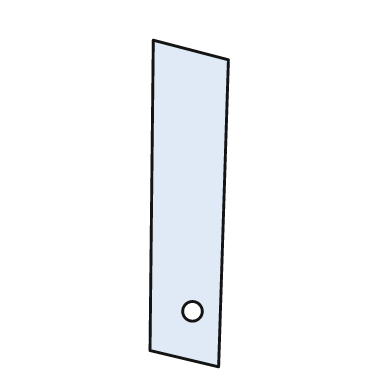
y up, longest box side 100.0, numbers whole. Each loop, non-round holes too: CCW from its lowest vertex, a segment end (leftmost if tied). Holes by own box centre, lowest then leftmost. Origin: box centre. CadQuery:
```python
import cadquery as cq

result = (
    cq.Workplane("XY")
    .moveTo(9.0, -50.0)
    .lineTo(12.0, 44.0)
    .lineTo(-11.0, 50.0)
    .lineTo(-12.0, -45.0)
    .close()
    .moveTo(1.0, -33.0)
    .circle(3.0)
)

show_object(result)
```